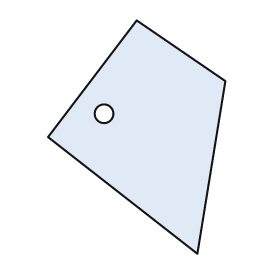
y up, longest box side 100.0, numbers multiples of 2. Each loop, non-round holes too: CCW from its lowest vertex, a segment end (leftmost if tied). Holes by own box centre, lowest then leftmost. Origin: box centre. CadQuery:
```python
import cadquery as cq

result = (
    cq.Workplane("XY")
    .moveTo(26.0, -50.0)
    .lineTo(38.0, 24.0)
    .lineTo(0.0, 50.0)
    .lineTo(-38.0, 0.0)
    .close()
    .moveTo(-14.0, 10.0)
    .circle(4.0)
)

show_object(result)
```